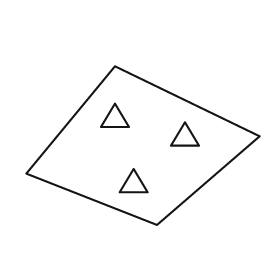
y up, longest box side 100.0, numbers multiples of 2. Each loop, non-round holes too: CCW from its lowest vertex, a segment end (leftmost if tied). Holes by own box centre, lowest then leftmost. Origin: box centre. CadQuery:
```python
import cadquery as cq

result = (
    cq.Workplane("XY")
    .moveTo(6.0, -34.0)
    .lineTo(50.0, 4.0)
    .lineTo(-12.0, 34.0)
    .lineTo(-50.0, -12.0)
    .close()
    .moveTo(-10.0, -20.0)
    .lineTo(2.0, -20.0)
    .lineTo(-4.0, -10.0)
    .close()
    .moveTo(12.0, 0.0)
    .lineTo(24.0, 0.0)
    .lineTo(18.0, 10.0)
    .close()
    .moveTo(-18.0, 8.0)
    .lineTo(-6.0, 8.0)
    .lineTo(-12.0, 18.0)
    .close()
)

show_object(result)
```